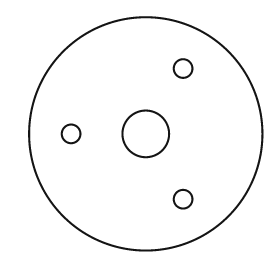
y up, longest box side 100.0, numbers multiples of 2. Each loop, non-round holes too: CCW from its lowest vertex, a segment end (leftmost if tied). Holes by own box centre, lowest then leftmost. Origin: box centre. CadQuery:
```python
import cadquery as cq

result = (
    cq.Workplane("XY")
    .moveTo(0.0, 0.0)
    .circle(50.0)
    .moveTo(16.0, -28.0)
    .circle(4.0)
    .moveTo(-32.0, 0.0)
    .circle(4.0)
    .moveTo(0.0, 0.0)
    .circle(10.0)
    .moveTo(16.0, 28.0)
    .circle(4.0)
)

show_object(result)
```